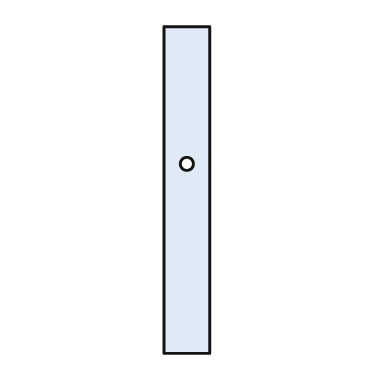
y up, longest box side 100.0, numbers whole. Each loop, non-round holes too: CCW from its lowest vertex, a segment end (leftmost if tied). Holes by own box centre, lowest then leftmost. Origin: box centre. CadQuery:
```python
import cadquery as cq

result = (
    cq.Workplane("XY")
    .moveTo(-7.0, -50.0)
    .lineTo(7.0, -50.0)
    .lineTo(7.0, 50.0)
    .lineTo(-7.0, 50.0)
    .close()
    .moveTo(0.0, 8.0)
    .circle(2.0)
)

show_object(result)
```